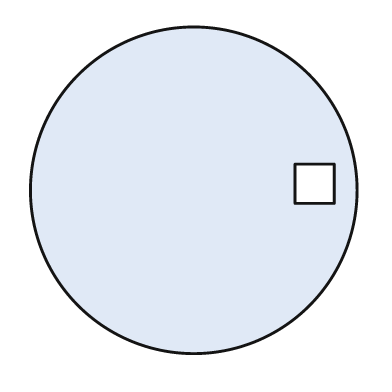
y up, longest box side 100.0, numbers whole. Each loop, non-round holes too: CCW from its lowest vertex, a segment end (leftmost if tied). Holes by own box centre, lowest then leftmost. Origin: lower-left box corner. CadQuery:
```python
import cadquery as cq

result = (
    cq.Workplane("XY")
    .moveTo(50.0, 50.0)
    .circle(50.0)
    .moveTo(81.0, 46.0)
    .lineTo(93.0, 46.0)
    .lineTo(93.0, 58.0)
    .lineTo(81.0, 58.0)
    .close()
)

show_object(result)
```